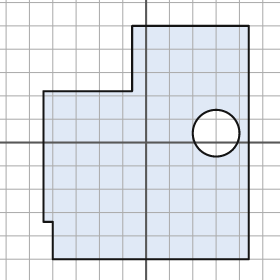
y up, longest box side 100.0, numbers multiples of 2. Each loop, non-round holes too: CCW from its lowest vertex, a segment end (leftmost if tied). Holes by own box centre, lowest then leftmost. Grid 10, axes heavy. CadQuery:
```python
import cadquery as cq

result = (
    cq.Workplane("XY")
    .moveTo(-40.0, -50.0)
    .lineTo(44.0, -50.0)
    .lineTo(44.0, 50.0)
    .lineTo(-6.0, 50.0)
    .lineTo(-6.0, 22.0)
    .lineTo(-44.0, 22.0)
    .lineTo(-44.0, -34.0)
    .lineTo(-40.0, -34.0)
    .close()
    .moveTo(30.0, 4.0)
    .circle(10.0)
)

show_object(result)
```